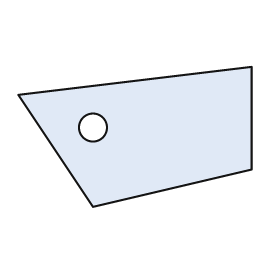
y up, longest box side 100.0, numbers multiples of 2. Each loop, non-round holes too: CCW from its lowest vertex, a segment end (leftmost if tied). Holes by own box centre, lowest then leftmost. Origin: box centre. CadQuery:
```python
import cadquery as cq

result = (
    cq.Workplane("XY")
    .moveTo(-18.0, -30.0)
    .lineTo(50.0, -14.0)
    .lineTo(50.0, 30.0)
    .lineTo(-50.0, 18.0)
    .close()
    .moveTo(-18.0, 4.0)
    .circle(6.0)
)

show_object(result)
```